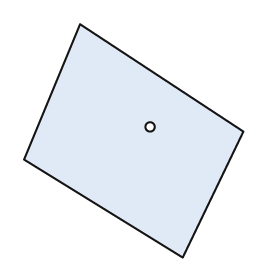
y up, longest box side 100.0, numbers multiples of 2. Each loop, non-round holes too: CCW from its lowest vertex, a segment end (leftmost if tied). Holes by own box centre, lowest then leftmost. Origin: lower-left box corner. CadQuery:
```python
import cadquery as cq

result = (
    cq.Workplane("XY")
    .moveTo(68.0, 0.0)
    .lineTo(94.0, 54.0)
    .lineTo(24.0, 100.0)
    .lineTo(0.0, 42.0)
    .close()
    .moveTo(54.0, 56.0)
    .circle(2.0)
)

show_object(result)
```